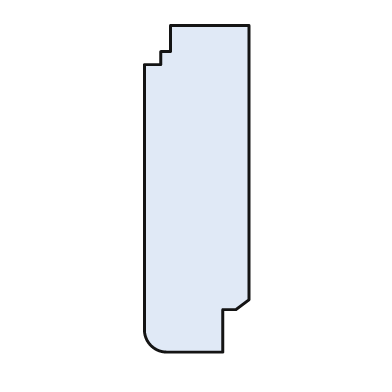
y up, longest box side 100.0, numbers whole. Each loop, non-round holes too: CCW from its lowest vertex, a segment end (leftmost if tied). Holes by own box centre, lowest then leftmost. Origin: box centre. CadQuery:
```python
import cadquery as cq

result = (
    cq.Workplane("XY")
    .moveTo(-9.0, -50.0)
    .lineTo(8.0, -50.0)
    .lineTo(8.0, -37.0)
    .lineTo(12.0, -37.0)
    .lineTo(16.0, -34.0)
    .lineTo(16.0, 50.0)
    .lineTo(-8.0, 50.0)
    .lineTo(-8.0, 42.0)
    .lineTo(-11.0, 42.0)
    .lineTo(-11.0, 38.0)
    .lineTo(-16.0, 38.0)
    .lineTo(-16.0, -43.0)
    .threePointArc((-14.0, -48.0), (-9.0, -50.0))
    .close()
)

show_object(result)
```